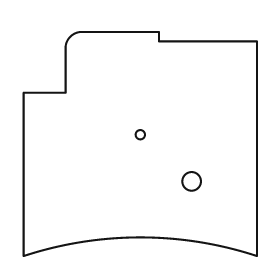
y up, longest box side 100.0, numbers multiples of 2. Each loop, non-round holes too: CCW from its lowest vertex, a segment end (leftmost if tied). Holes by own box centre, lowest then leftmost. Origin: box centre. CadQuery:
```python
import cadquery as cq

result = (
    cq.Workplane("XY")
    .moveTo(-50.0, -48.0)
    .threePointArc((0.0, -40.0), (50.0, -48.0))
    .lineTo(50.0, 44.0)
    .lineTo(8.0, 44.0)
    .lineTo(8.0, 48.0)
    .lineTo(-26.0, 48.0)
    .threePointArc((-30.0, 46.0), (-32.0, 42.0))
    .lineTo(-32.0, 22.0)
    .lineTo(-50.0, 22.0)
    .close()
    .moveTo(22.0, -16.0)
    .circle(4.0)
    .moveTo(0.0, 4.0)
    .circle(2.0)
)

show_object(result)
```